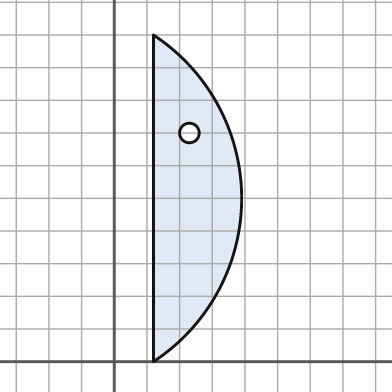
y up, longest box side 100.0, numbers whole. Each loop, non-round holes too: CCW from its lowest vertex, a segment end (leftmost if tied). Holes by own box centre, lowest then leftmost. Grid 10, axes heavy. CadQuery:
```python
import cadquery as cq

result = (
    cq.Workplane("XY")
    .moveTo(12.0, 0.0)
    .threePointArc((39.0, 50.0), (12.0, 100.0))
    .close()
    .moveTo(23.0, 70.0)
    .circle(3.0)
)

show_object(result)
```